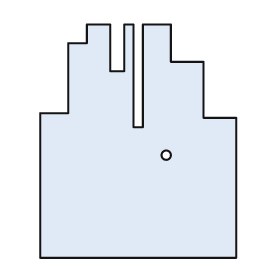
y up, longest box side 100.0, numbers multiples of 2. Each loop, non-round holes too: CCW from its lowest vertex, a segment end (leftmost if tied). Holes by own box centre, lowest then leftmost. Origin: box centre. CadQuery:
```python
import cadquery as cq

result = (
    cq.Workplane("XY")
    .moveTo(-42.0, -50.0)
    .lineTo(42.0, -50.0)
    .lineTo(42.0, 10.0)
    .lineTo(28.0, 10.0)
    .lineTo(28.0, 34.0)
    .lineTo(14.0, 34.0)
    .lineTo(14.0, 50.0)
    .lineTo(2.0, 50.0)
    .lineTo(2.0, 6.0)
    .lineTo(-2.0, 6.0)
    .lineTo(-2.0, 50.0)
    .lineTo(-6.0, 50.0)
    .lineTo(-6.0, 30.0)
    .lineTo(-12.0, 30.0)
    .lineTo(-12.0, 50.0)
    .lineTo(-22.0, 50.0)
    .lineTo(-22.0, 42.0)
    .lineTo(-30.0, 42.0)
    .lineTo(-30.0, 12.0)
    .lineTo(-42.0, 12.0)
    .close()
    .moveTo(12.0, -6.0)
    .circle(2.0)
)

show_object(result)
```